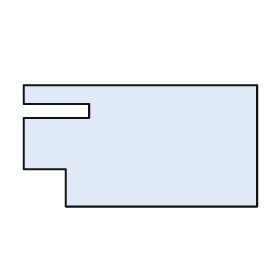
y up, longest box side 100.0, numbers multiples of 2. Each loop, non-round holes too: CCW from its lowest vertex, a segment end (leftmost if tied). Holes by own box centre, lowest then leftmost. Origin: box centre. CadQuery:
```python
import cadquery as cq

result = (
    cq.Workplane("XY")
    .moveTo(-32.0, -26.0)
    .lineTo(50.0, -26.0)
    .lineTo(50.0, 26.0)
    .lineTo(-50.0, 26.0)
    .lineTo(-50.0, 18.0)
    .lineTo(-22.0, 18.0)
    .lineTo(-22.0, 12.0)
    .lineTo(-50.0, 12.0)
    .lineTo(-50.0, -10.0)
    .lineTo(-32.0, -10.0)
    .close()
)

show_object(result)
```